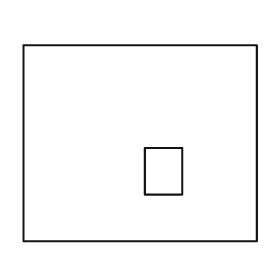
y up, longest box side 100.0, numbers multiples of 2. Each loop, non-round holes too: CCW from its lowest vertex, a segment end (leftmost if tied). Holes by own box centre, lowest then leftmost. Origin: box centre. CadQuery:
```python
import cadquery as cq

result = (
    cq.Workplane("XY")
    .moveTo(-50.0, -42.0)
    .lineTo(50.0, -42.0)
    .lineTo(50.0, 42.0)
    .lineTo(-50.0, 42.0)
    .close()
    .moveTo(2.0, -22.0)
    .lineTo(18.0, -22.0)
    .lineTo(18.0, -2.0)
    .lineTo(2.0, -2.0)
    .close()
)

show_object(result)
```